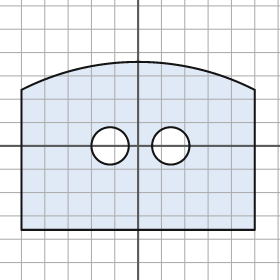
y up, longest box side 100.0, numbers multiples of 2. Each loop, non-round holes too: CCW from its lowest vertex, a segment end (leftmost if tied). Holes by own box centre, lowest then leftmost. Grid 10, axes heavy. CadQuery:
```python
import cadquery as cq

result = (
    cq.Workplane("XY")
    .moveTo(-50.0, -36.0)
    .lineTo(50.0, -36.0)
    .lineTo(50.0, 24.0)
    .threePointArc((0.0, 36.0), (-50.0, 24.0))
    .close()
    .moveTo(-12.0, 0.0)
    .circle(8.0)
    .moveTo(14.0, 0.0)
    .circle(8.0)
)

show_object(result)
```